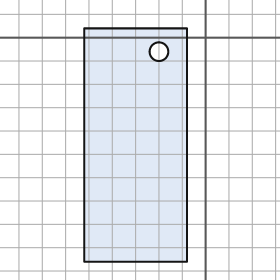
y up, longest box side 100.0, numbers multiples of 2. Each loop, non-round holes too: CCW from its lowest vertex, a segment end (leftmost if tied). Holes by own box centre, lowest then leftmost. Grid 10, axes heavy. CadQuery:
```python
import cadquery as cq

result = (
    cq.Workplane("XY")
    .moveTo(-52.0, -96.0)
    .lineTo(-8.0, -96.0)
    .lineTo(-8.0, 4.0)
    .lineTo(-52.0, 4.0)
    .close()
    .moveTo(-20.0, -6.0)
    .circle(4.0)
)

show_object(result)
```